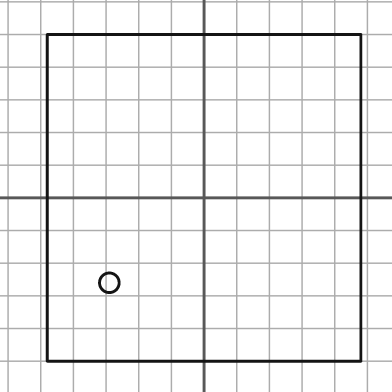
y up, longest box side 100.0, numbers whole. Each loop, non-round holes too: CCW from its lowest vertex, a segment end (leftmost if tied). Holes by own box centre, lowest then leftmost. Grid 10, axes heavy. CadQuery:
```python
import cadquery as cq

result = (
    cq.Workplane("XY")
    .moveTo(-48.0, -50.0)
    .lineTo(48.0, -50.0)
    .lineTo(48.0, 50.0)
    .lineTo(-48.0, 50.0)
    .close()
    .moveTo(-29.0, -26.0)
    .circle(3.0)
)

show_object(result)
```